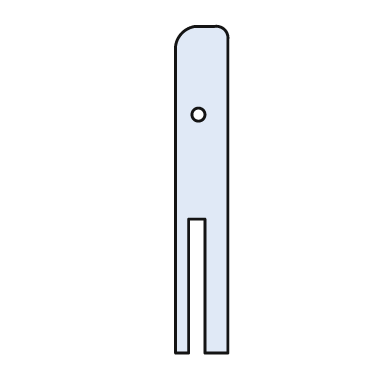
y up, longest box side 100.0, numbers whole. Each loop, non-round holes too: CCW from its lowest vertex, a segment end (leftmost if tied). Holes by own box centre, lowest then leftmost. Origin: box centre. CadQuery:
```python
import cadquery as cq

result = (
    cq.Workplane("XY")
    .moveTo(-8.0, -50.0)
    .lineTo(-4.0, -50.0)
    .lineTo(-4.0, -9.0)
    .lineTo(1.0, -9.0)
    .lineTo(1.0, -50.0)
    .lineTo(8.0, -50.0)
    .lineTo(8.0, 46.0)
    .threePointArc((7.0, 49.0), (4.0, 50.0))
    .lineTo(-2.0, 50.0)
    .threePointArc((-6.0, 48.0), (-8.0, 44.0))
    .close()
    .moveTo(-1.0, 23.0)
    .circle(2.0)
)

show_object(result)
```